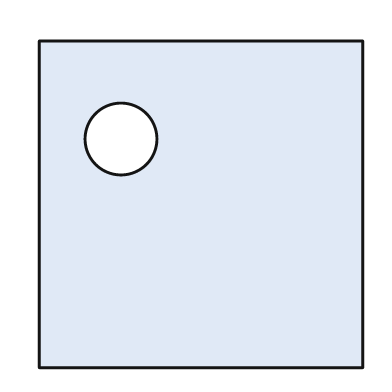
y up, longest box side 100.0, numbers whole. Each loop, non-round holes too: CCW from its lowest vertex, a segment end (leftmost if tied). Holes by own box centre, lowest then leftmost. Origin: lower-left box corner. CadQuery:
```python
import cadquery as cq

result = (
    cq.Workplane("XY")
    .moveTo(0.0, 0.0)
    .lineTo(99.0, 0.0)
    .lineTo(99.0, 100.0)
    .lineTo(0.0, 100.0)
    .close()
    .moveTo(25.0, 70.0)
    .circle(11.0)
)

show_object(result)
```